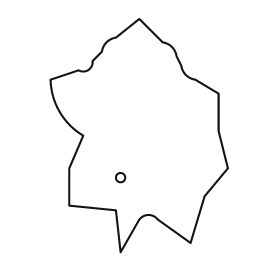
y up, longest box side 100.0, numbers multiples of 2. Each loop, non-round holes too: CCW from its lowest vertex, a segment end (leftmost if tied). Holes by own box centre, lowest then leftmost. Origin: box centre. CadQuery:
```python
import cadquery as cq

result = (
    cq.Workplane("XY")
    .moveTo(-8.0, -50.0)
    .lineTo(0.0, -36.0)
    .threePointArc((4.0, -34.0), (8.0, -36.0))
    .lineTo(22.0, -46.0)
    .lineTo(28.0, -26.0)
    .lineTo(38.0, -14.0)
    .lineTo(34.0, 2.0)
    .lineTo(34.0, 18.0)
    .lineTo(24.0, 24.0)
    .threePointArc((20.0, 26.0), (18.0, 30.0))
    .lineTo(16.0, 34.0)
    .threePointArc((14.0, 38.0), (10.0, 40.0))
    .lineTo(0.0, 50.0)
    .lineTo(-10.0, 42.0)
    .threePointArc((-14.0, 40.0), (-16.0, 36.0))
    .lineTo(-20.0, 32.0)
    .threePointArc((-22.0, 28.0), (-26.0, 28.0))
    .lineTo(-38.0, 24.0)
    .threePointArc((-34.0, 10.0), (-24.0, 0.0))
    .lineTo(-30.0, -14.0)
    .lineTo(-30.0, -30.0)
    .lineTo(-10.0, -32.0)
    .close()
    .moveTo(-8.0, -18.0)
    .circle(2.0)
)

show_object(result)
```